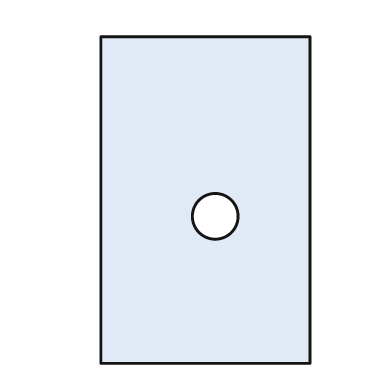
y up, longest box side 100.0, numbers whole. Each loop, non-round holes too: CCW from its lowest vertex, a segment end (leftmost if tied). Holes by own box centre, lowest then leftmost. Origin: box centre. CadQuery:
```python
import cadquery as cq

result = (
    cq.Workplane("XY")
    .moveTo(-32.0, -50.0)
    .lineTo(32.0, -50.0)
    .lineTo(32.0, 50.0)
    .lineTo(-32.0, 50.0)
    .close()
    .moveTo(3.0, -5.0)
    .circle(7.0)
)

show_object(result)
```